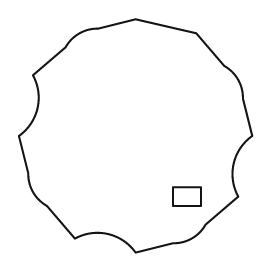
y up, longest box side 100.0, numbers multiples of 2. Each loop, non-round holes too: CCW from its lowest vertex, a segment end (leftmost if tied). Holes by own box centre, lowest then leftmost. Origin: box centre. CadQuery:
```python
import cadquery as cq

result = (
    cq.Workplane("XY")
    .moveTo(0.0, -50.0)
    .lineTo(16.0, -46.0)
    .threePointArc((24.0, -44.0), (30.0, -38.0))
    .lineTo(44.0, -26.0)
    .threePointArc((42.0, -12.0), (50.0, 0.0))
    .lineTo(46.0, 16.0)
    .threePointArc((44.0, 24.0), (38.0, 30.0))
    .lineTo(26.0, 44.0)
    .lineTo(0.0, 50.0)
    .lineTo(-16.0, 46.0)
    .threePointArc((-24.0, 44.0), (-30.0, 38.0))
    .lineTo(-44.0, 26.0)
    .threePointArc((-42.0, 12.0), (-50.0, 0.0))
    .lineTo(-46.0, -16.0)
    .threePointArc((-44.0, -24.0), (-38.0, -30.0))
    .lineTo(-26.0, -44.0)
    .threePointArc((-12.0, -42.0), (0.0, -50.0))
    .close()
    .moveTo(16.0, -30.0)
    .lineTo(28.0, -30.0)
    .lineTo(28.0, -22.0)
    .lineTo(16.0, -22.0)
    .close()
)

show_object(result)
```